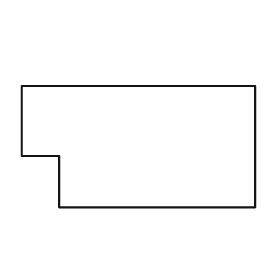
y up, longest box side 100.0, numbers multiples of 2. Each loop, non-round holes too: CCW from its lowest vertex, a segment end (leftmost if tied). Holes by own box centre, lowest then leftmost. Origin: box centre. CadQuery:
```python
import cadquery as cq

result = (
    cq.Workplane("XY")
    .moveTo(-34.0, -26.0)
    .lineTo(50.0, -26.0)
    .lineTo(50.0, 26.0)
    .lineTo(-50.0, 26.0)
    .lineTo(-50.0, -4.0)
    .lineTo(-34.0, -4.0)
    .close()
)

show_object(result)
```